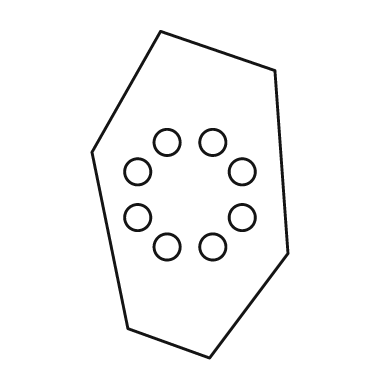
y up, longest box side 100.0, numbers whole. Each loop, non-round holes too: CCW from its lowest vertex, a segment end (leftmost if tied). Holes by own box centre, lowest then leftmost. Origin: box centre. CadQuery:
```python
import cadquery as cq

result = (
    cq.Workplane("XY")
    .moveTo(6.0, -50.0)
    .lineTo(30.0, -18.0)
    .lineTo(26.0, 38.0)
    .lineTo(-9.0, 50.0)
    .lineTo(-30.0, 13.0)
    .lineTo(-19.0, -41.0)
    .close()
    .moveTo(-7.0, -16.0)
    .circle(4.0)
    .moveTo(7.0, -16.0)
    .circle(4.0)
    .moveTo(-16.0, -7.0)
    .circle(4.0)
    .moveTo(16.0, -7.0)
    .circle(4.0)
    .moveTo(-16.0, 7.0)
    .circle(4.0)
    .moveTo(16.0, 7.0)
    .circle(4.0)
    .moveTo(-7.0, 16.0)
    .circle(4.0)
    .moveTo(7.0, 16.0)
    .circle(4.0)
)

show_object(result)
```